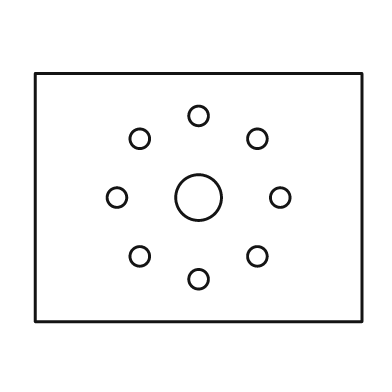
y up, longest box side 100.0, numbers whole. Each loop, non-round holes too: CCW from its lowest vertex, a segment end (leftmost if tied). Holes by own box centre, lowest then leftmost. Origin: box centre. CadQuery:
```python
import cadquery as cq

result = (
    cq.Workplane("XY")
    .moveTo(-50.0, -38.0)
    .lineTo(50.0, -38.0)
    .lineTo(50.0, 38.0)
    .lineTo(-50.0, 38.0)
    .close()
    .moveTo(0.0, -25.0)
    .circle(3.0)
    .moveTo(-18.0, -18.0)
    .circle(3.0)
    .moveTo(18.0, -18.0)
    .circle(3.0)
    .moveTo(-25.0, 0.0)
    .circle(3.0)
    .moveTo(0.0, 0.0)
    .circle(7.0)
    .moveTo(25.0, 0.0)
    .circle(3.0)
    .moveTo(-18.0, 18.0)
    .circle(3.0)
    .moveTo(18.0, 18.0)
    .circle(3.0)
    .moveTo(0.0, 25.0)
    .circle(3.0)
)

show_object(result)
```